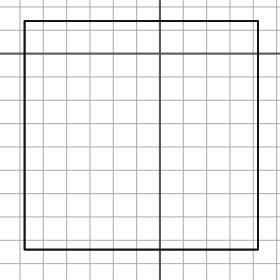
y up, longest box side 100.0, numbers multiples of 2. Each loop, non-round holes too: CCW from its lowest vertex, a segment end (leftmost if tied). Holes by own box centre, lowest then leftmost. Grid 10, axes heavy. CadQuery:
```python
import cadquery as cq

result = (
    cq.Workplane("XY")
    .moveTo(-58.0, -84.0)
    .lineTo(42.0, -84.0)
    .lineTo(42.0, 14.0)
    .lineTo(-58.0, 14.0)
    .close()
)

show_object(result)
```